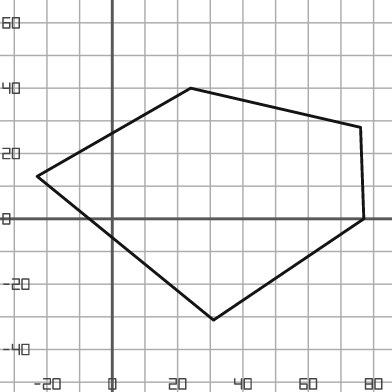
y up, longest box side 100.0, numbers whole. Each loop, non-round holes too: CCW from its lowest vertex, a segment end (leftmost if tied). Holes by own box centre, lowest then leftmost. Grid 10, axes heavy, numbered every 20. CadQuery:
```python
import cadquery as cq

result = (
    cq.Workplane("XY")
    .moveTo(31.0, -31.0)
    .lineTo(77.0, 0.0)
    .lineTo(76.0, 28.0)
    .lineTo(24.0, 40.0)
    .lineTo(-23.0, 13.0)
    .close()
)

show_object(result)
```